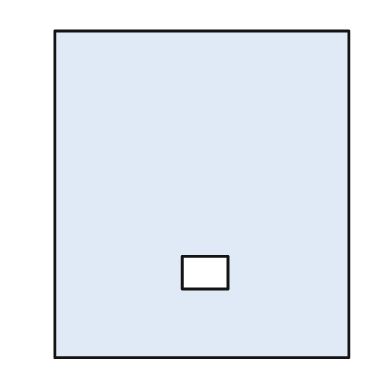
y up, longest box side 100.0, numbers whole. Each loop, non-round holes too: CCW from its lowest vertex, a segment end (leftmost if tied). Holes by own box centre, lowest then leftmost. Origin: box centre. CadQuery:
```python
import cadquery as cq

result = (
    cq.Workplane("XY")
    .moveTo(-45.0, -50.0)
    .lineTo(45.0, -50.0)
    .lineTo(45.0, 50.0)
    .lineTo(-45.0, 50.0)
    .close()
    .moveTo(-6.0, -29.0)
    .lineTo(8.0, -29.0)
    .lineTo(8.0, -19.0)
    .lineTo(-6.0, -19.0)
    .close()
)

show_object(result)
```